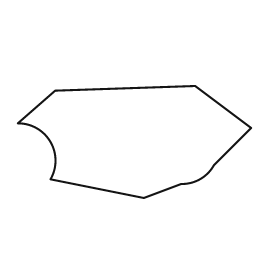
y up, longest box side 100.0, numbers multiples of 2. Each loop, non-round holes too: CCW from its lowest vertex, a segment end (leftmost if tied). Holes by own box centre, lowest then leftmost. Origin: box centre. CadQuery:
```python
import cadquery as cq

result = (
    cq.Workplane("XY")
    .moveTo(4.0, -24.0)
    .lineTo(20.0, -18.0)
    .threePointArc((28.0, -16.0), (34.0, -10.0))
    .lineTo(50.0, 6.0)
    .lineTo(26.0, 24.0)
    .lineTo(-34.0, 22.0)
    .lineTo(-50.0, 8.0)
    .threePointArc((-36.0, 0.0), (-36.0, -16.0))
    .close()
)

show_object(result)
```